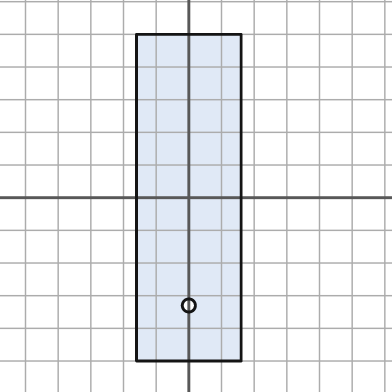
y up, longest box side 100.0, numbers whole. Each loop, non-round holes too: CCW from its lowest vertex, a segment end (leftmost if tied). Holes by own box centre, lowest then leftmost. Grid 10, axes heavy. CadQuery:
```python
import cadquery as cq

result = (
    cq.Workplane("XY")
    .moveTo(-16.0, -50.0)
    .lineTo(16.0, -50.0)
    .lineTo(16.0, 50.0)
    .lineTo(-16.0, 50.0)
    .close()
    .moveTo(0.0, -33.0)
    .circle(2.0)
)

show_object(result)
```